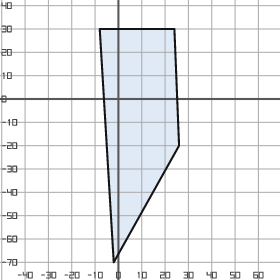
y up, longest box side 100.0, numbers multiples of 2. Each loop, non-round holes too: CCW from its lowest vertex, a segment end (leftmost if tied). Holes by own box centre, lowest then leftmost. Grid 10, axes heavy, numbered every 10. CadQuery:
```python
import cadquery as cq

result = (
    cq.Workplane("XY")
    .moveTo(-2.0, -70.0)
    .lineTo(26.0, -20.0)
    .lineTo(24.0, 30.0)
    .lineTo(-8.0, 30.0)
    .close()
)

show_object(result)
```